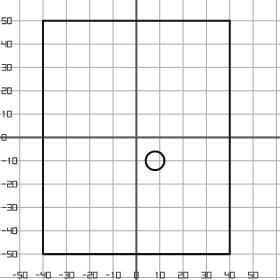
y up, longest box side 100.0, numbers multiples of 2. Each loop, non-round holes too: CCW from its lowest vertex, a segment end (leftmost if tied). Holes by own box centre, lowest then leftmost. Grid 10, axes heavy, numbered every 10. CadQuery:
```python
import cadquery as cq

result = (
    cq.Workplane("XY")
    .moveTo(-40.0, -50.0)
    .lineTo(40.0, -50.0)
    .lineTo(40.0, 50.0)
    .lineTo(-40.0, 50.0)
    .close()
    .moveTo(8.0, -10.0)
    .circle(4.0)
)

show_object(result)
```